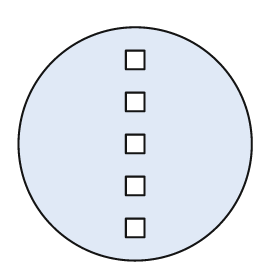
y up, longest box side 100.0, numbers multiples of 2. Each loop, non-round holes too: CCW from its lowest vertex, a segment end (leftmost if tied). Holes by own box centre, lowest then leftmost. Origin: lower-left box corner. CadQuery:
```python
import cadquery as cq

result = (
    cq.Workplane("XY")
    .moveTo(50.0, 50.0)
    .circle(50.0)
    .moveTo(46.0, 10.0)
    .lineTo(54.0, 10.0)
    .lineTo(54.0, 18.0)
    .lineTo(46.0, 18.0)
    .close()
    .moveTo(46.0, 28.0)
    .lineTo(54.0, 28.0)
    .lineTo(54.0, 36.0)
    .lineTo(46.0, 36.0)
    .close()
    .moveTo(46.0, 46.0)
    .lineTo(54.0, 46.0)
    .lineTo(54.0, 54.0)
    .lineTo(46.0, 54.0)
    .close()
    .moveTo(46.0, 64.0)
    .lineTo(54.0, 64.0)
    .lineTo(54.0, 72.0)
    .lineTo(46.0, 72.0)
    .close()
    .moveTo(46.0, 82.0)
    .lineTo(54.0, 82.0)
    .lineTo(54.0, 90.0)
    .lineTo(46.0, 90.0)
    .close()
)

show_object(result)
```